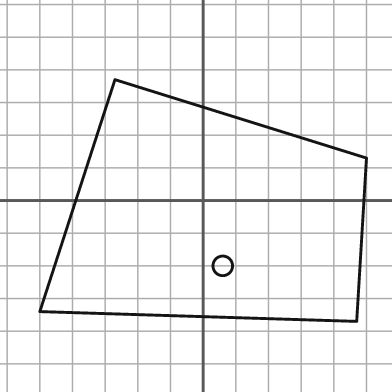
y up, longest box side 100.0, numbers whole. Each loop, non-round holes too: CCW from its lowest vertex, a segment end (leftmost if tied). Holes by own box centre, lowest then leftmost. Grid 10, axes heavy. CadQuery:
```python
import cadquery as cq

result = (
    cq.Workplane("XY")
    .moveTo(47.0, -37.0)
    .lineTo(50.0, 13.0)
    .lineTo(-27.0, 37.0)
    .lineTo(-50.0, -34.0)
    .close()
    .moveTo(6.0, -20.0)
    .circle(3.0)
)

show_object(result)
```